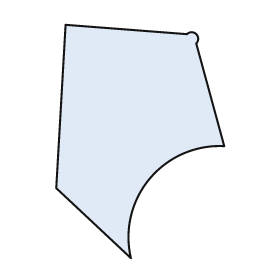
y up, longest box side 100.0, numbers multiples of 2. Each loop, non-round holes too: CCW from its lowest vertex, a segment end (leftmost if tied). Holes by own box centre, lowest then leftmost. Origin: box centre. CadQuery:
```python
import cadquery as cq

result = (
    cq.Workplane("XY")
    .moveTo(-4.0, -50.0)
    .threePointArc((4.0, -16.0), (36.0, -2.0))
    .lineTo(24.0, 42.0)
    .threePointArc((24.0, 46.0), (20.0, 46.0))
    .lineTo(-32.0, 50.0)
    .lineTo(-36.0, -20.0)
    .close()
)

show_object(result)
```